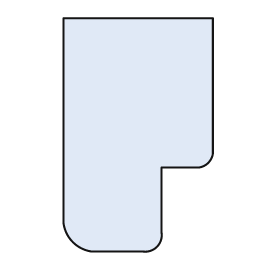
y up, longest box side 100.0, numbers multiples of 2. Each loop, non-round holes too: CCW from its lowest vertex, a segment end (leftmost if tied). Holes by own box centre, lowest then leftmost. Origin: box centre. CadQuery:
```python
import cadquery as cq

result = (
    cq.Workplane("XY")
    .moveTo(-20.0, -50.0)
    .lineTo(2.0, -50.0)
    .threePointArc((8.0, -48.0), (10.0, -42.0))
    .lineTo(10.0, -14.0)
    .lineTo(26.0, -14.0)
    .threePointArc((30.0, -12.0), (32.0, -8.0))
    .lineTo(32.0, 50.0)
    .lineTo(-32.0, 50.0)
    .lineTo(-32.0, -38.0)
    .threePointArc((-28.0, -46.0), (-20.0, -50.0))
    .close()
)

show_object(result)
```